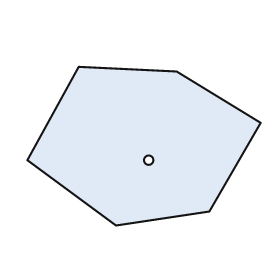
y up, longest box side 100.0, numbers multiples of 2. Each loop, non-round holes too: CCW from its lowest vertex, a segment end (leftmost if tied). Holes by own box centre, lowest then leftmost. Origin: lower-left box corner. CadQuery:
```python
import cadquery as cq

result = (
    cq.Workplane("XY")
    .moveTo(38.0, 0.0)
    .lineTo(78.0, 6.0)
    .lineTo(100.0, 44.0)
    .lineTo(64.0, 66.0)
    .lineTo(22.0, 68.0)
    .lineTo(0.0, 28.0)
    .close()
    .moveTo(52.0, 28.0)
    .circle(2.0)
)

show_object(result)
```